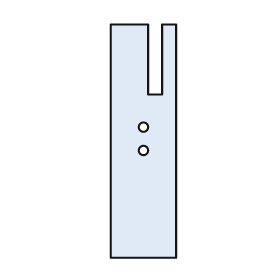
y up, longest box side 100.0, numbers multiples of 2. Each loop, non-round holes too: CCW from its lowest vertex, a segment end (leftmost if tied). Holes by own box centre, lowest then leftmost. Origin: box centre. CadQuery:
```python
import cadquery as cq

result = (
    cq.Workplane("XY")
    .moveTo(-14.0, -50.0)
    .lineTo(14.0, -50.0)
    .lineTo(14.0, 50.0)
    .lineTo(8.0, 50.0)
    .lineTo(8.0, 20.0)
    .lineTo(2.0, 20.0)
    .lineTo(2.0, 50.0)
    .lineTo(-14.0, 50.0)
    .close()
    .moveTo(0.0, -4.0)
    .circle(2.0)
    .moveTo(0.0, 6.0)
    .circle(2.0)
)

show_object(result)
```